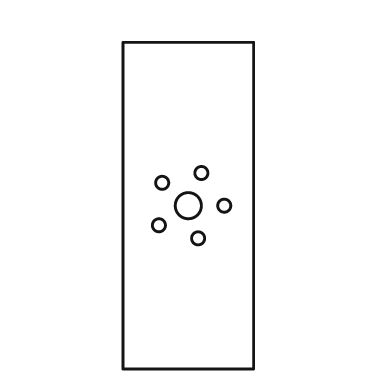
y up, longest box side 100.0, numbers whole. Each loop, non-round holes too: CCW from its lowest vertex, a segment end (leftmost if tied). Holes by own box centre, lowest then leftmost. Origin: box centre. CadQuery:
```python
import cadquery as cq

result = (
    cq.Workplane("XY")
    .moveTo(-20.0, -50.0)
    .lineTo(20.0, -50.0)
    .lineTo(20.0, 50.0)
    .lineTo(-20.0, 50.0)
    .close()
    .moveTo(3.0, -10.0)
    .circle(2.0)
    .moveTo(-9.0, -6.0)
    .circle(2.0)
    .moveTo(0.0, 0.0)
    .circle(4.0)
    .moveTo(11.0, 0.0)
    .circle(2.0)
    .moveTo(-8.0, 7.0)
    .circle(2.0)
    .moveTo(4.0, 10.0)
    .circle(2.0)
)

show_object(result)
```